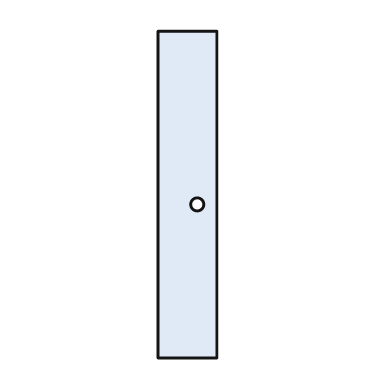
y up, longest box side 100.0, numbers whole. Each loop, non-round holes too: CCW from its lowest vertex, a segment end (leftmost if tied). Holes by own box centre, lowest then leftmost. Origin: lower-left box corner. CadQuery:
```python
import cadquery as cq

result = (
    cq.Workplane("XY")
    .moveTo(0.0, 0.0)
    .lineTo(18.0, 0.0)
    .lineTo(18.0, 100.0)
    .lineTo(0.0, 100.0)
    .close()
    .moveTo(12.0, 47.0)
    .circle(2.0)
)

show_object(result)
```